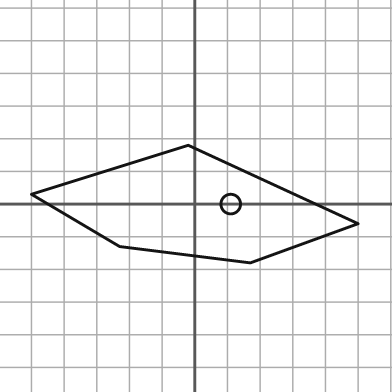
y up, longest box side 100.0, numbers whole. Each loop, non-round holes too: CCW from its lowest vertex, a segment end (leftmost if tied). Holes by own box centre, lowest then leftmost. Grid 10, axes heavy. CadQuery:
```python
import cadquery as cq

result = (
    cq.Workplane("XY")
    .moveTo(17.0, -18.0)
    .lineTo(50.0, -6.0)
    .lineTo(-2.0, 18.0)
    .lineTo(-50.0, 3.0)
    .lineTo(-23.0, -13.0)
    .close()
    .moveTo(11.0, 0.0)
    .circle(3.0)
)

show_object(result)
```